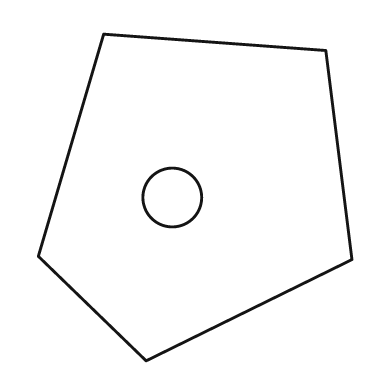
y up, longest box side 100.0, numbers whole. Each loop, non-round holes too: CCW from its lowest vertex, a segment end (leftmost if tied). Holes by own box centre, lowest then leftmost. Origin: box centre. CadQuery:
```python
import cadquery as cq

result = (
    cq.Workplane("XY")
    .moveTo(-15.0, -50.0)
    .lineTo(48.0, -19.0)
    .lineTo(40.0, 45.0)
    .lineTo(-28.0, 50.0)
    .lineTo(-48.0, -18.0)
    .close()
    .moveTo(-7.0, 0.0)
    .circle(9.0)
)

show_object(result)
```